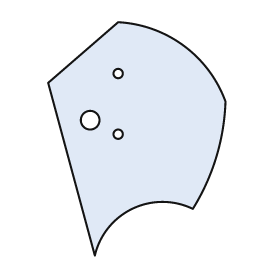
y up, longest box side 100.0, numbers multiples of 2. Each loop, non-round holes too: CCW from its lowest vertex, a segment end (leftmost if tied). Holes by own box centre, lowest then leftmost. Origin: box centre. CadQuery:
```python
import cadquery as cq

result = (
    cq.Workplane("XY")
    .moveTo(-18.0, -50.0)
    .threePointArc((-2.0, -30.0), (24.0, -30.0))
    .threePointArc((34.0, -8.0), (38.0, 16.0))
    .threePointArc((20.0, 40.0), (-8.0, 50.0))
    .lineTo(-38.0, 24.0)
    .close()
    .moveTo(-8.0, 2.0)
    .circle(2.0)
    .moveTo(-20.0, 8.0)
    .circle(4.0)
    .moveTo(-8.0, 28.0)
    .circle(2.0)
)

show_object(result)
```